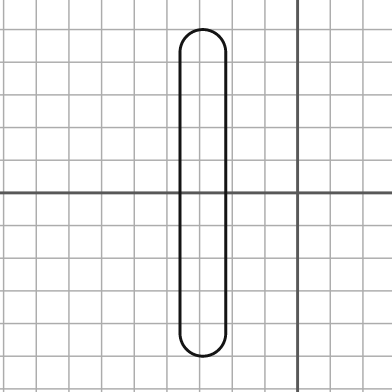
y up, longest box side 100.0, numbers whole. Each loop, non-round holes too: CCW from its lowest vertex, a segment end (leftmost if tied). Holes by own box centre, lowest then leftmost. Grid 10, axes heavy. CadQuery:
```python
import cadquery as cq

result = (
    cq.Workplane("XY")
    .moveTo(-36.0, -43.0)
    .threePointArc((-29.0, -50.0), (-22.0, -43.0))
    .lineTo(-22.0, 43.0)
    .threePointArc((-29.0, 50.0), (-36.0, 43.0))
    .close()
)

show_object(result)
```